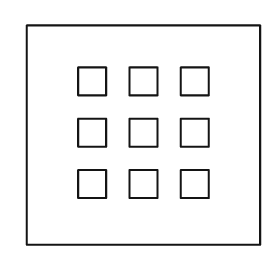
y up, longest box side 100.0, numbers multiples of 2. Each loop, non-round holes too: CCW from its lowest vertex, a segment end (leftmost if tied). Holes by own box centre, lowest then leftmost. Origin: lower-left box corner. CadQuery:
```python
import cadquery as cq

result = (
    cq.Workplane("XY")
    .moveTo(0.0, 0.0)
    .lineTo(100.0, 0.0)
    .lineTo(100.0, 94.0)
    .lineTo(0.0, 94.0)
    .close()
    .moveTo(22.0, 20.0)
    .lineTo(34.0, 20.0)
    .lineTo(34.0, 32.0)
    .lineTo(22.0, 32.0)
    .close()
    .moveTo(44.0, 20.0)
    .lineTo(56.0, 20.0)
    .lineTo(56.0, 32.0)
    .lineTo(44.0, 32.0)
    .close()
    .moveTo(66.0, 20.0)
    .lineTo(78.0, 20.0)
    .lineTo(78.0, 32.0)
    .lineTo(66.0, 32.0)
    .close()
    .moveTo(22.0, 42.0)
    .lineTo(34.0, 42.0)
    .lineTo(34.0, 54.0)
    .lineTo(22.0, 54.0)
    .close()
    .moveTo(44.0, 42.0)
    .lineTo(56.0, 42.0)
    .lineTo(56.0, 54.0)
    .lineTo(44.0, 54.0)
    .close()
    .moveTo(66.0, 42.0)
    .lineTo(78.0, 42.0)
    .lineTo(78.0, 54.0)
    .lineTo(66.0, 54.0)
    .close()
    .moveTo(22.0, 64.0)
    .lineTo(34.0, 64.0)
    .lineTo(34.0, 76.0)
    .lineTo(22.0, 76.0)
    .close()
    .moveTo(44.0, 64.0)
    .lineTo(56.0, 64.0)
    .lineTo(56.0, 76.0)
    .lineTo(44.0, 76.0)
    .close()
    .moveTo(66.0, 64.0)
    .lineTo(78.0, 64.0)
    .lineTo(78.0, 76.0)
    .lineTo(66.0, 76.0)
    .close()
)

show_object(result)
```